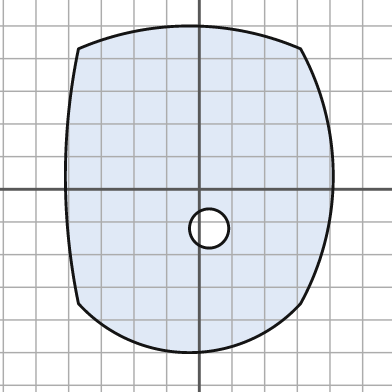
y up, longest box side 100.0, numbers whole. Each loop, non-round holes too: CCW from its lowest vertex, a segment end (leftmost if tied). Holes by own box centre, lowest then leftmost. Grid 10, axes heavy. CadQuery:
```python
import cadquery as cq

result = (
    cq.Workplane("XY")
    .moveTo(-37.0, -35.0)
    .threePointArc((-3.0, -50.0), (31.0, -35.0))
    .threePointArc((41.0, 4.0), (31.0, 43.0))
    .threePointArc((-3.0, 50.0), (-37.0, 43.0))
    .threePointArc((-41.0, 4.0), (-37.0, -35.0))
    .close()
    .moveTo(3.0, -12.0)
    .circle(6.0)
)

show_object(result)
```